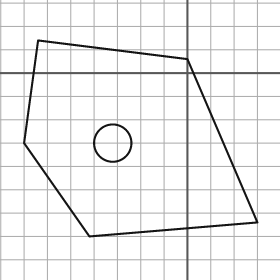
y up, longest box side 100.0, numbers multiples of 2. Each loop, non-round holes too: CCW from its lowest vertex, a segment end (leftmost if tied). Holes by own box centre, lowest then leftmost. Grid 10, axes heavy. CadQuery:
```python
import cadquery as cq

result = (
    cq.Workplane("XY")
    .moveTo(-42.0, -70.0)
    .lineTo(30.0, -64.0)
    .lineTo(0.0, 6.0)
    .lineTo(-64.0, 14.0)
    .lineTo(-70.0, -30.0)
    .close()
    .moveTo(-32.0, -30.0)
    .circle(8.0)
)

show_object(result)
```